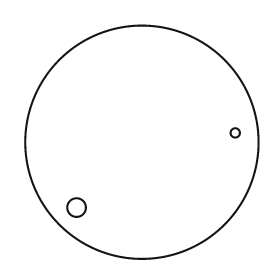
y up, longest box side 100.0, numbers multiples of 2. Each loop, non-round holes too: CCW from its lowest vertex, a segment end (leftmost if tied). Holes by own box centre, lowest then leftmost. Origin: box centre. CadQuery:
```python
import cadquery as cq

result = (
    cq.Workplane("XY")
    .moveTo(0.0, 0.0)
    .circle(50.0)
    .moveTo(-28.0, -28.0)
    .circle(4.0)
    .moveTo(40.0, 4.0)
    .circle(2.0)
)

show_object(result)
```